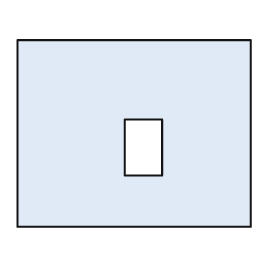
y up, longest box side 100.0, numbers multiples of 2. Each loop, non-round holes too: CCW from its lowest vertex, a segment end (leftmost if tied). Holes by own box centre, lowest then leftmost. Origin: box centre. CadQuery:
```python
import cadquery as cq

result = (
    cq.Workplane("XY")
    .moveTo(-50.0, -40.0)
    .lineTo(50.0, -40.0)
    .lineTo(50.0, 40.0)
    .lineTo(-50.0, 40.0)
    .close()
    .moveTo(-4.0, -18.0)
    .lineTo(12.0, -18.0)
    .lineTo(12.0, 6.0)
    .lineTo(-4.0, 6.0)
    .close()
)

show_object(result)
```